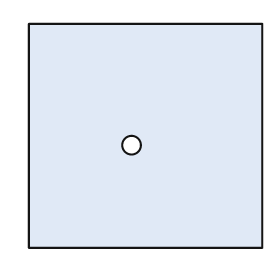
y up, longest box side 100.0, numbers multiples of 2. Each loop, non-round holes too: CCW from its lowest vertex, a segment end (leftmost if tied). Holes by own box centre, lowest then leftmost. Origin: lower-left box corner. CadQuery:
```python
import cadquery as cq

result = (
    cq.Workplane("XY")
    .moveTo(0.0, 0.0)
    .lineTo(100.0, 0.0)
    .lineTo(100.0, 96.0)
    .lineTo(0.0, 96.0)
    .close()
    .moveTo(44.0, 44.0)
    .circle(4.0)
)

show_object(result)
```